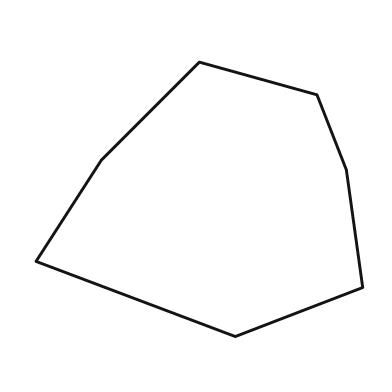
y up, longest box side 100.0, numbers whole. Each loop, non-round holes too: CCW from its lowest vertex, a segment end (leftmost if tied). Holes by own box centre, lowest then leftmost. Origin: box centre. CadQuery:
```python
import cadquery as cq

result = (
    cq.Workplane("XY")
    .moveTo(11.0, -42.0)
    .lineTo(50.0, -27.0)
    .lineTo(45.0, 9.0)
    .lineTo(36.0, 32.0)
    .lineTo(0.0, 42.0)
    .lineTo(-30.0, 12.0)
    .lineTo(-50.0, -19.0)
    .close()
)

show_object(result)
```